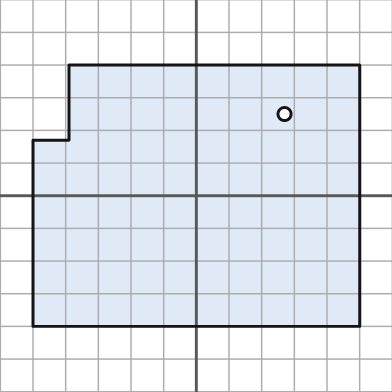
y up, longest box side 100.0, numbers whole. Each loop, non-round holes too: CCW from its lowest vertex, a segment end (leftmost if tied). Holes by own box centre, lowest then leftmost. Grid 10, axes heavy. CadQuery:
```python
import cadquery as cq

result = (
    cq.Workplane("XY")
    .moveTo(-50.0, -40.0)
    .lineTo(50.0, -40.0)
    .lineTo(50.0, 40.0)
    .lineTo(-39.0, 40.0)
    .lineTo(-39.0, 17.0)
    .lineTo(-50.0, 17.0)
    .close()
    .moveTo(27.0, 25.0)
    .circle(2.0)
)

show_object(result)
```